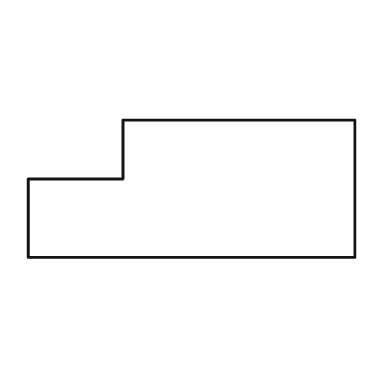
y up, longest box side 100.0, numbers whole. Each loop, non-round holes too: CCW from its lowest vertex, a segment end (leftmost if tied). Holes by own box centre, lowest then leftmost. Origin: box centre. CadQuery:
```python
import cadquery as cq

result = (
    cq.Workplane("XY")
    .moveTo(-50.0, -21.0)
    .lineTo(50.0, -21.0)
    .lineTo(50.0, 21.0)
    .lineTo(-21.0, 21.0)
    .lineTo(-21.0, 3.0)
    .lineTo(-50.0, 3.0)
    .close()
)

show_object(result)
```